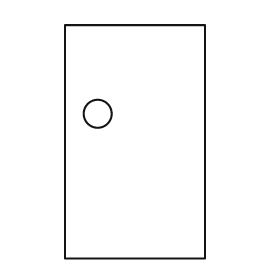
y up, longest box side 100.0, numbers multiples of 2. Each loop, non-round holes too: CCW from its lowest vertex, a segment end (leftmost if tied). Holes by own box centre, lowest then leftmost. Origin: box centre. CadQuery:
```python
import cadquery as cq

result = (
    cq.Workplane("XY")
    .moveTo(-30.0, -50.0)
    .lineTo(30.0, -50.0)
    .lineTo(30.0, 50.0)
    .lineTo(-30.0, 50.0)
    .close()
    .moveTo(-16.0, 12.0)
    .circle(6.0)
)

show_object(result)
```